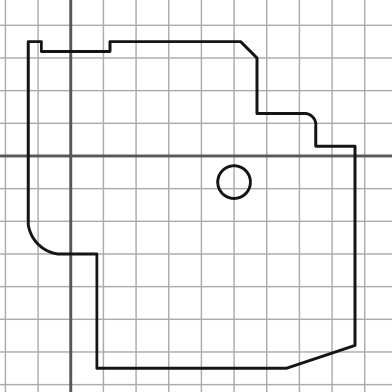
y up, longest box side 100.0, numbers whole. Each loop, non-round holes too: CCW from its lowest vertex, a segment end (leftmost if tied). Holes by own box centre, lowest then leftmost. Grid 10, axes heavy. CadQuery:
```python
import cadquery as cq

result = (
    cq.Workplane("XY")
    .moveTo(8.0, -65.0)
    .lineTo(66.0, -65.0)
    .lineTo(87.0, -58.0)
    .lineTo(87.0, 3.0)
    .lineTo(75.0, 3.0)
    .lineTo(75.0, 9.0)
    .threePointArc((74.0, 12.0), (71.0, 13.0))
    .lineTo(57.0, 13.0)
    .lineTo(57.0, 30.0)
    .lineTo(52.0, 35.0)
    .lineTo(12.0, 35.0)
    .lineTo(12.0, 32.0)
    .lineTo(-9.0, 32.0)
    .lineTo(-9.0, 35.0)
    .lineTo(-13.0, 35.0)
    .lineTo(-13.0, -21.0)
    .threePointArc((-10.0, -27.0), (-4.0, -30.0))
    .lineTo(8.0, -30.0)
    .close()
    .moveTo(50.0, -8.0)
    .circle(5.0)
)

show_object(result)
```